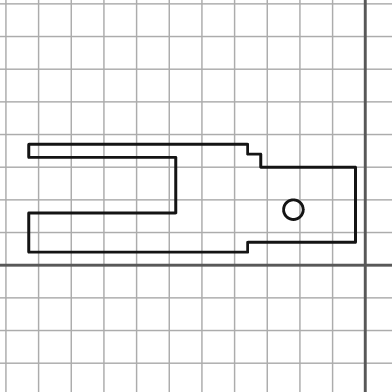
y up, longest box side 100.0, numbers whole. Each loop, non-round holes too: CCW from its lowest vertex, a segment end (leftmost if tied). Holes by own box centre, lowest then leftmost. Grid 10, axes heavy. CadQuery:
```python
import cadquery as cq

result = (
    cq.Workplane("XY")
    .moveTo(-103.0, 4.0)
    .lineTo(-36.0, 4.0)
    .lineTo(-36.0, 7.0)
    .lineTo(-3.0, 7.0)
    .lineTo(-3.0, 30.0)
    .lineTo(-32.0, 30.0)
    .lineTo(-32.0, 34.0)
    .lineTo(-36.0, 34.0)
    .lineTo(-36.0, 37.0)
    .lineTo(-103.0, 37.0)
    .lineTo(-103.0, 33.0)
    .lineTo(-58.0, 33.0)
    .lineTo(-58.0, 16.0)
    .lineTo(-103.0, 16.0)
    .close()
    .moveTo(-22.0, 17.0)
    .circle(3.0)
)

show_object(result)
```